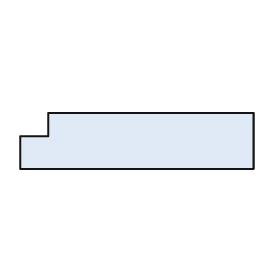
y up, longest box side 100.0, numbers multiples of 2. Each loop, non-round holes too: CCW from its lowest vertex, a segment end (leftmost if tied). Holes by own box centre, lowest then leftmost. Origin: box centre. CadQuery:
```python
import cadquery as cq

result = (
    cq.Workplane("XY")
    .moveTo(-50.0, -12.0)
    .lineTo(50.0, -12.0)
    .lineTo(50.0, 12.0)
    .lineTo(-38.0, 12.0)
    .lineTo(-38.0, 2.0)
    .lineTo(-50.0, 2.0)
    .close()
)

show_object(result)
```